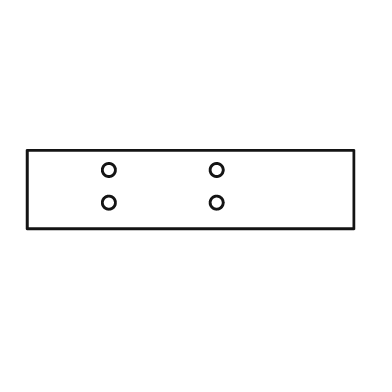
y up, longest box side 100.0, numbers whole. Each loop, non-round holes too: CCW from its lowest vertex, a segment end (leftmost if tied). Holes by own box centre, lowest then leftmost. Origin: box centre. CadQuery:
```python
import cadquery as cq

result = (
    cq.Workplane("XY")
    .moveTo(-50.0, -12.0)
    .lineTo(50.0, -12.0)
    .lineTo(50.0, 12.0)
    .lineTo(-50.0, 12.0)
    .close()
    .moveTo(-25.0, -4.0)
    .circle(2.0)
    .moveTo(8.0, -4.0)
    .circle(2.0)
    .moveTo(-25.0, 6.0)
    .circle(2.0)
    .moveTo(8.0, 6.0)
    .circle(2.0)
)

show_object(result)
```